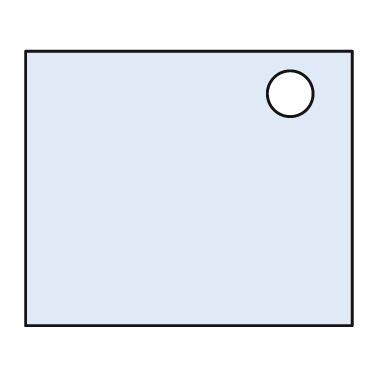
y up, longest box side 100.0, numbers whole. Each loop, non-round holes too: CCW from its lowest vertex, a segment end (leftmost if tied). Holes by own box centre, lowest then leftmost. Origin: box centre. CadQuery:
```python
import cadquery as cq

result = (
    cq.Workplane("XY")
    .moveTo(-50.0, -42.0)
    .lineTo(50.0, -42.0)
    .lineTo(50.0, 42.0)
    .lineTo(-50.0, 42.0)
    .close()
    .moveTo(31.0, 29.0)
    .circle(7.0)
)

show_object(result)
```